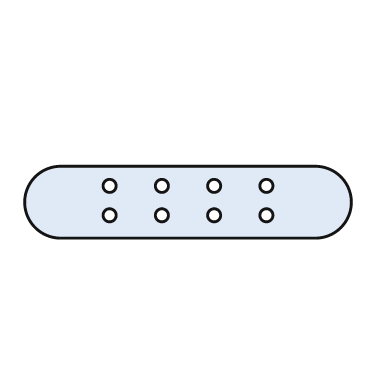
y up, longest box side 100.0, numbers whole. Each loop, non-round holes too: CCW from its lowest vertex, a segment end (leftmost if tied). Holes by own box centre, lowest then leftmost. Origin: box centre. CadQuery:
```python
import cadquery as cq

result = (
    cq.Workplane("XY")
    .moveTo(-39.0, -11.0)
    .lineTo(39.0, -11.0)
    .threePointArc((50.0, 0.0), (39.0, 11.0))
    .lineTo(-39.0, 11.0)
    .threePointArc((-50.0, 0.0), (-39.0, -11.0))
    .close()
    .moveTo(-24.0, -4.0)
    .circle(2.0)
    .moveTo(-8.0, -4.0)
    .circle(2.0)
    .moveTo(8.0, -4.0)
    .circle(2.0)
    .moveTo(24.0, -4.0)
    .circle(2.0)
    .moveTo(-24.0, 5.0)
    .circle(2.0)
    .moveTo(-8.0, 5.0)
    .circle(2.0)
    .moveTo(8.0, 5.0)
    .circle(2.0)
    .moveTo(24.0, 5.0)
    .circle(2.0)
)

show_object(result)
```